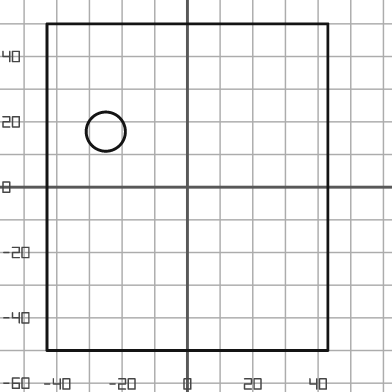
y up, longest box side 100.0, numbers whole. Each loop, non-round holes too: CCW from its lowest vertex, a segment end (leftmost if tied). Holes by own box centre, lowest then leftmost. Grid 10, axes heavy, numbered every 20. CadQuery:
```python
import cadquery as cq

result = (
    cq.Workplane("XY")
    .moveTo(-43.0, -50.0)
    .lineTo(43.0, -50.0)
    .lineTo(43.0, 50.0)
    .lineTo(-43.0, 50.0)
    .close()
    .moveTo(-25.0, 17.0)
    .circle(6.0)
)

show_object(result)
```